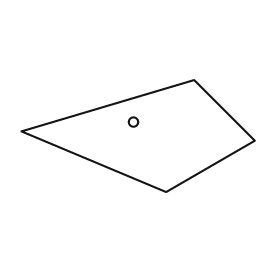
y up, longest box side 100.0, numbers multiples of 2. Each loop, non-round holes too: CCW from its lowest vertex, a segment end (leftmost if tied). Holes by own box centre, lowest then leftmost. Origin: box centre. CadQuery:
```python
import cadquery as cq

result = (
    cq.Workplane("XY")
    .moveTo(12.0, -24.0)
    .lineTo(50.0, -2.0)
    .lineTo(24.0, 24.0)
    .lineTo(-50.0, 2.0)
    .close()
    .moveTo(-2.0, 6.0)
    .circle(2.0)
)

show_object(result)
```